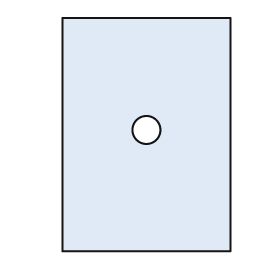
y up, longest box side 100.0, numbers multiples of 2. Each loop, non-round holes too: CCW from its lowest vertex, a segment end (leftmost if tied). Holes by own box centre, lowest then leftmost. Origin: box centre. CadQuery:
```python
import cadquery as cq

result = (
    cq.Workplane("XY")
    .moveTo(-36.0, -50.0)
    .lineTo(36.0, -50.0)
    .lineTo(36.0, 50.0)
    .lineTo(-36.0, 50.0)
    .close()
    .moveTo(0.0, 2.0)
    .circle(6.0)
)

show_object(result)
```